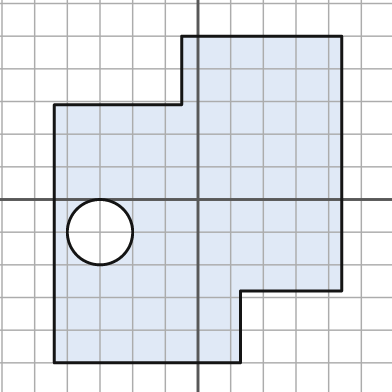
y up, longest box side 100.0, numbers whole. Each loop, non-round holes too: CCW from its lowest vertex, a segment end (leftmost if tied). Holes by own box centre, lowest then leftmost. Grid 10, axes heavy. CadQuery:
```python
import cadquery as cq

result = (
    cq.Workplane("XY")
    .moveTo(-44.0, -50.0)
    .lineTo(13.0, -50.0)
    .lineTo(13.0, -28.0)
    .lineTo(44.0, -28.0)
    .lineTo(44.0, 50.0)
    .lineTo(-5.0, 50.0)
    .lineTo(-5.0, 29.0)
    .lineTo(-44.0, 29.0)
    .close()
    .moveTo(-30.0, -10.0)
    .circle(10.0)
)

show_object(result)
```